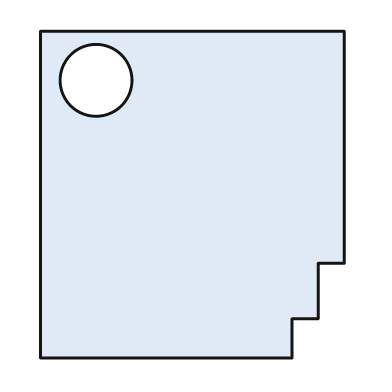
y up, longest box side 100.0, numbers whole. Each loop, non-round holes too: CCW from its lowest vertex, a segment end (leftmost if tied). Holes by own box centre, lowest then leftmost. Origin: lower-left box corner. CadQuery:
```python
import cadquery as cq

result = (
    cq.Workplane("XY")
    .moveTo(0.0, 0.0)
    .lineTo(77.0, 0.0)
    .lineTo(77.0, 12.0)
    .lineTo(85.0, 12.0)
    .lineTo(85.0, 29.0)
    .lineTo(93.0, 29.0)
    .lineTo(93.0, 100.0)
    .lineTo(0.0, 100.0)
    .close()
    .moveTo(17.0, 85.0)
    .circle(11.0)
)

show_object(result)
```